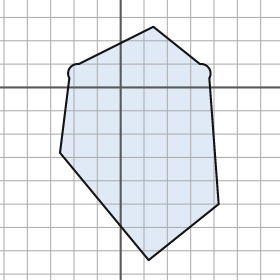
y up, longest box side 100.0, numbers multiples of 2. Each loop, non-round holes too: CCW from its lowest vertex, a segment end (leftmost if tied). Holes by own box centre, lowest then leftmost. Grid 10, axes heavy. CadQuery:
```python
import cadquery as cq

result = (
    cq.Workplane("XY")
    .moveTo(12.0, -74.0)
    .lineTo(42.0, -50.0)
    .lineTo(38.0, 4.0)
    .threePointArc((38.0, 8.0), (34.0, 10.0))
    .lineTo(14.0, 26.0)
    .lineTo(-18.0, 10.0)
    .threePointArc((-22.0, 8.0), (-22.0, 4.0))
    .lineTo(-26.0, -28.0)
    .close()
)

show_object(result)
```